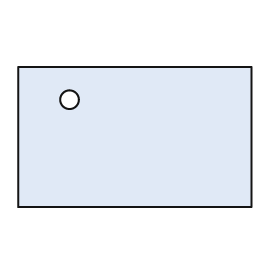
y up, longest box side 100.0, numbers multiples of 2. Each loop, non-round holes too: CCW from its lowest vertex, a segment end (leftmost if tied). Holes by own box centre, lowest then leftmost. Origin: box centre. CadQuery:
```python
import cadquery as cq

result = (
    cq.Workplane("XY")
    .moveTo(-50.0, -30.0)
    .lineTo(50.0, -30.0)
    .lineTo(50.0, 30.0)
    .lineTo(-50.0, 30.0)
    .close()
    .moveTo(-28.0, 16.0)
    .circle(4.0)
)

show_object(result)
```